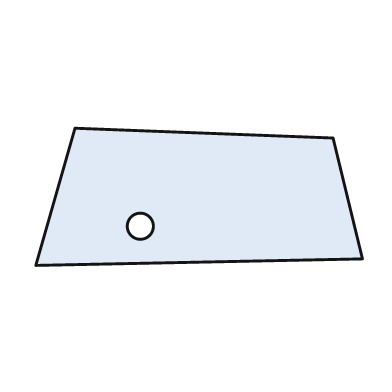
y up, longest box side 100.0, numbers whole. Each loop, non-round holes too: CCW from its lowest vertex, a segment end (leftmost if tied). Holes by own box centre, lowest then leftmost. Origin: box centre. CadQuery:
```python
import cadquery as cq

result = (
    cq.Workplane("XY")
    .moveTo(-50.0, -21.0)
    .lineTo(50.0, -19.0)
    .lineTo(41.0, 18.0)
    .lineTo(-38.0, 21.0)
    .close()
    .moveTo(-18.0, -9.0)
    .circle(4.0)
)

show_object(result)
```